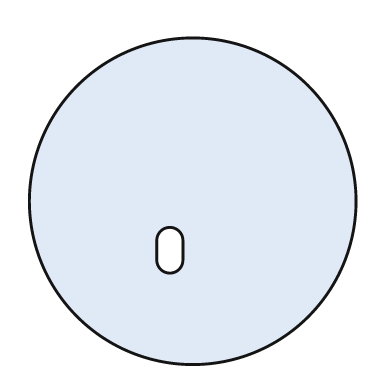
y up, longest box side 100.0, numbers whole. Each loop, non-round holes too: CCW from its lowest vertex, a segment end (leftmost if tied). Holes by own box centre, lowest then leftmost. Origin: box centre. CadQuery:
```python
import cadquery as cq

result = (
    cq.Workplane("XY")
    .moveTo(0.0, 0.0)
    .circle(50.0)
    .moveTo(-11.0, -18.0)
    .threePointArc((-7.0, -22.0), (-3.0, -18.0))
    .lineTo(-3.0, -12.0)
    .threePointArc((-7.0, -8.0), (-11.0, -12.0))
    .close()
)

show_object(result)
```